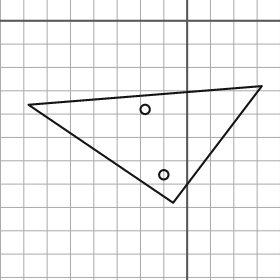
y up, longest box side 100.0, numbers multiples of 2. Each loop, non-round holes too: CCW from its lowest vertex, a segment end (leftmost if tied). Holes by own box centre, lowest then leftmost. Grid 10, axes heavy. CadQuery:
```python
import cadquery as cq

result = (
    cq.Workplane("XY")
    .moveTo(-6.0, -78.0)
    .lineTo(32.0, -28.0)
    .lineTo(-68.0, -36.0)
    .close()
    .moveTo(-10.0, -66.0)
    .circle(2.0)
    .moveTo(-18.0, -38.0)
    .circle(2.0)
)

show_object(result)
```